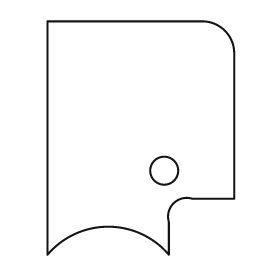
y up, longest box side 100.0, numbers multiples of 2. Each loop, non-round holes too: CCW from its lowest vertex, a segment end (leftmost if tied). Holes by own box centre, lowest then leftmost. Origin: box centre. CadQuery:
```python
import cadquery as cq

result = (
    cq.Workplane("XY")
    .moveTo(-40.0, -50.0)
    .threePointArc((-14.0, -38.0), (12.0, -50.0))
    .lineTo(12.0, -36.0)
    .threePointArc((14.0, -28.0), (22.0, -26.0))
    .lineTo(40.0, -26.0)
    .lineTo(40.0, 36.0)
    .threePointArc((36.0, 46.0), (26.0, 50.0))
    .lineTo(-40.0, 50.0)
    .close()
    .moveTo(10.0, -14.0)
    .circle(6.0)
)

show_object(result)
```